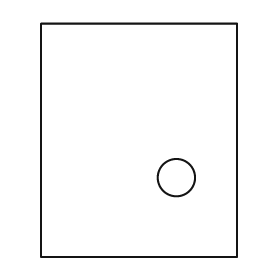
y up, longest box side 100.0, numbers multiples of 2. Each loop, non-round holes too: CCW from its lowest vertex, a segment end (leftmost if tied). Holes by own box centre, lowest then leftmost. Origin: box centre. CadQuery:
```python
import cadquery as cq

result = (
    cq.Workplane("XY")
    .moveTo(-42.0, -50.0)
    .lineTo(42.0, -50.0)
    .lineTo(42.0, 50.0)
    .lineTo(-42.0, 50.0)
    .close()
    .moveTo(16.0, -16.0)
    .circle(8.0)
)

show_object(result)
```